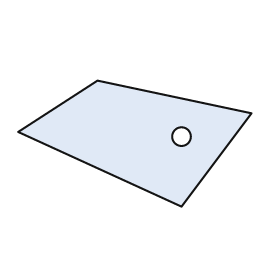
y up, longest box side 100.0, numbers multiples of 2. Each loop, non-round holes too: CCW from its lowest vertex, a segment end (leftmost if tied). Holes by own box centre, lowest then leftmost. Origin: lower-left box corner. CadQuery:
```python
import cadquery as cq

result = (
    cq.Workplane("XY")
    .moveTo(70.0, 0.0)
    .lineTo(100.0, 40.0)
    .lineTo(34.0, 54.0)
    .lineTo(0.0, 32.0)
    .close()
    .moveTo(70.0, 30.0)
    .circle(4.0)
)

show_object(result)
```